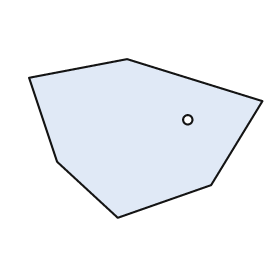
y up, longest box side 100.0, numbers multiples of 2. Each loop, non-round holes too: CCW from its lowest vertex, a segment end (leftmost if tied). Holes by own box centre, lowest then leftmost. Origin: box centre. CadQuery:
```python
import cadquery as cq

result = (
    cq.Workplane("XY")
    .moveTo(-12.0, -34.0)
    .lineTo(28.0, -20.0)
    .lineTo(50.0, 16.0)
    .lineTo(-8.0, 34.0)
    .lineTo(-50.0, 26.0)
    .lineTo(-38.0, -10.0)
    .close()
    .moveTo(18.0, 8.0)
    .circle(2.0)
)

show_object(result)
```